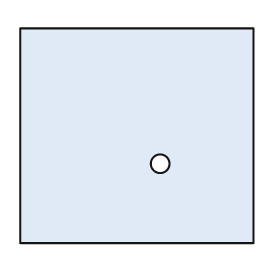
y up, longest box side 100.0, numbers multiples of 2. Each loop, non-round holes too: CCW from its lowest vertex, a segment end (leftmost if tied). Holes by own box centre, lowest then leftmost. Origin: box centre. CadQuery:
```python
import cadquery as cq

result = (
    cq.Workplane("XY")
    .moveTo(-50.0, -46.0)
    .lineTo(50.0, -46.0)
    .lineTo(50.0, 46.0)
    .lineTo(-50.0, 46.0)
    .close()
    .moveTo(10.0, -12.0)
    .circle(4.0)
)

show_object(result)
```